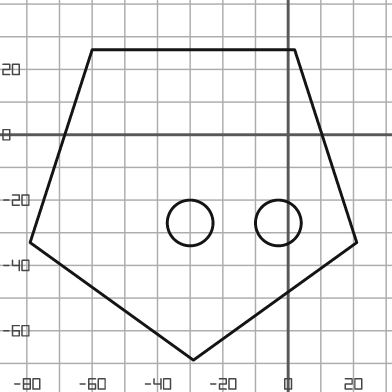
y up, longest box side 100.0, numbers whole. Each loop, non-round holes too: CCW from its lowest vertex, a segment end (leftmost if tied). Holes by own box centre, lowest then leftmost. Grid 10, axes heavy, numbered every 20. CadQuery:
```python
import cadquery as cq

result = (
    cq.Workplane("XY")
    .moveTo(-29.0, -69.0)
    .lineTo(21.0, -33.0)
    .lineTo(2.0, 26.0)
    .lineTo(-60.0, 26.0)
    .lineTo(-79.0, -33.0)
    .close()
    .moveTo(-30.0, -27.0)
    .circle(7.0)
    .moveTo(-3.0, -27.0)
    .circle(7.0)
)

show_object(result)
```